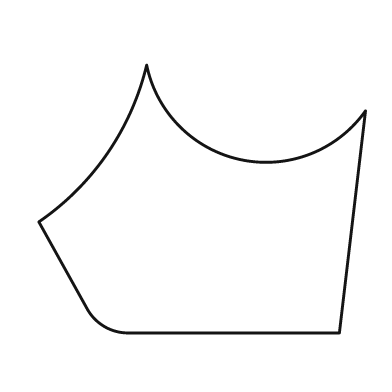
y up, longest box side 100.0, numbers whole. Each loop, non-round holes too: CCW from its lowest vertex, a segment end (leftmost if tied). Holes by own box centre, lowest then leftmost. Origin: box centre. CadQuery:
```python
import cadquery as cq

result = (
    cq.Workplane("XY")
    .moveTo(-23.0, -41.0)
    .lineTo(42.0, -41.0)
    .lineTo(50.0, 27.0)
    .threePointArc((12.0, 12.0), (-17.0, 41.0))
    .threePointArc((-29.0, 14.0), (-50.0, -7.0))
    .lineTo(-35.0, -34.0)
    .threePointArc((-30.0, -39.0), (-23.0, -41.0))
    .close()
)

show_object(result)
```